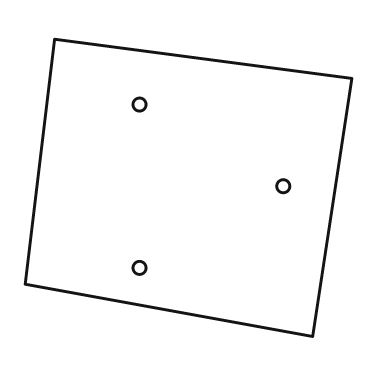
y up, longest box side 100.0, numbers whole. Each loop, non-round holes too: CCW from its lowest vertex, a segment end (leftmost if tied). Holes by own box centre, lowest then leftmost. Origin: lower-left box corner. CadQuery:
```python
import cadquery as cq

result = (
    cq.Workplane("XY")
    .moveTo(88.0, 0.0)
    .lineTo(100.0, 79.0)
    .lineTo(9.0, 91.0)
    .lineTo(0.0, 16.0)
    .close()
    .moveTo(35.0, 21.0)
    .circle(2.0)
    .moveTo(79.0, 46.0)
    .circle(2.0)
    .moveTo(35.0, 71.0)
    .circle(2.0)
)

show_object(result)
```